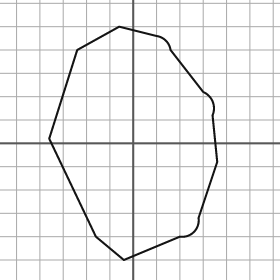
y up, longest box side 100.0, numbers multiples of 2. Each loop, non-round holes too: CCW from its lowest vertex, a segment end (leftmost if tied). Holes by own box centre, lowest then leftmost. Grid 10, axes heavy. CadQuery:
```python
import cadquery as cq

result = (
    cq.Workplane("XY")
    .moveTo(-4.0, -50.0)
    .lineTo(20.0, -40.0)
    .threePointArc((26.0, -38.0), (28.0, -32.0))
    .lineTo(36.0, -8.0)
    .lineTo(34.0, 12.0)
    .threePointArc((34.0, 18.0), (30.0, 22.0))
    .lineTo(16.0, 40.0)
    .threePointArc((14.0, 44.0), (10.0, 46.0))
    .lineTo(-6.0, 50.0)
    .lineTo(-24.0, 40.0)
    .lineTo(-36.0, 2.0)
    .lineTo(-16.0, -40.0)
    .close()
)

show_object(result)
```